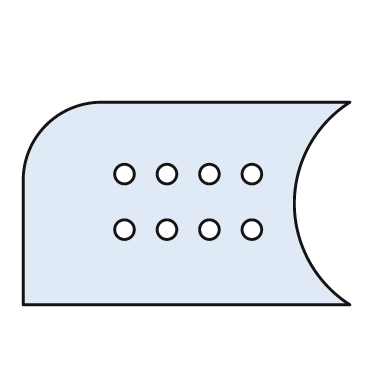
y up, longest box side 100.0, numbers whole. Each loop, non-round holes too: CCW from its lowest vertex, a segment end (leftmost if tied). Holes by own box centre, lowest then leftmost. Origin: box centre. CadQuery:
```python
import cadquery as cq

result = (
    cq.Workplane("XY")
    .moveTo(-50.0, -31.0)
    .lineTo(50.0, -31.0)
    .threePointArc((33.0, 0.0), (50.0, 31.0))
    .lineTo(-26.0, 31.0)
    .threePointArc((-43.0, 24.0), (-50.0, 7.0))
    .close()
    .moveTo(-19.0, -8.0)
    .circle(3.0)
    .moveTo(-6.0, -8.0)
    .circle(3.0)
    .moveTo(7.0, -8.0)
    .circle(3.0)
    .moveTo(20.0, -8.0)
    .circle(3.0)
    .moveTo(-19.0, 9.0)
    .circle(3.0)
    .moveTo(-6.0, 9.0)
    .circle(3.0)
    .moveTo(7.0, 9.0)
    .circle(3.0)
    .moveTo(20.0, 9.0)
    .circle(3.0)
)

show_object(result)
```